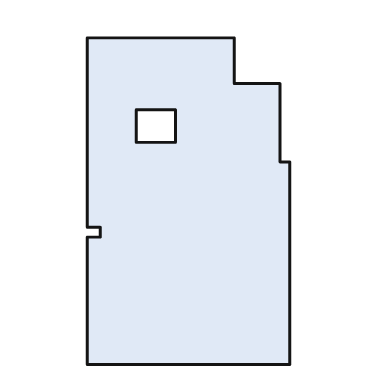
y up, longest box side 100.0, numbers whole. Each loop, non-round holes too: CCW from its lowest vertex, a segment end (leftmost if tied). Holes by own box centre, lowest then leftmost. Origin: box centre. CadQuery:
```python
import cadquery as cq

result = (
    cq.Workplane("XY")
    .moveTo(-31.0, -50.0)
    .lineTo(31.0, -50.0)
    .lineTo(31.0, 12.0)
    .lineTo(28.0, 12.0)
    .lineTo(28.0, 36.0)
    .lineTo(14.0, 36.0)
    .lineTo(14.0, 50.0)
    .lineTo(-31.0, 50.0)
    .lineTo(-31.0, -8.0)
    .lineTo(-27.0, -8.0)
    .lineTo(-27.0, -11.0)
    .lineTo(-31.0, -11.0)
    .close()
    .moveTo(-16.0, 18.0)
    .lineTo(-4.0, 18.0)
    .lineTo(-4.0, 28.0)
    .lineTo(-16.0, 28.0)
    .close()
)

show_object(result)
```